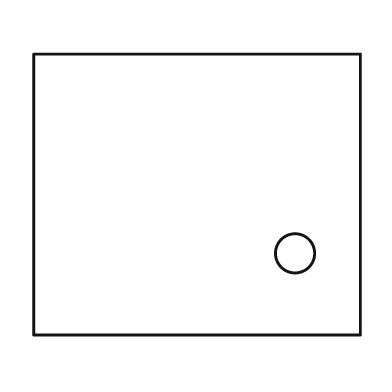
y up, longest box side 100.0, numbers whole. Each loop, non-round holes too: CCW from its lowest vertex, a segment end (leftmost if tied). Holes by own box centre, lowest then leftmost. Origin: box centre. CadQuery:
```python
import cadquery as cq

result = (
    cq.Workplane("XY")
    .moveTo(-50.0, -43.0)
    .lineTo(50.0, -43.0)
    .lineTo(50.0, 43.0)
    .lineTo(-50.0, 43.0)
    .close()
    .moveTo(30.0, -18.0)
    .circle(6.0)
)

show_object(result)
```